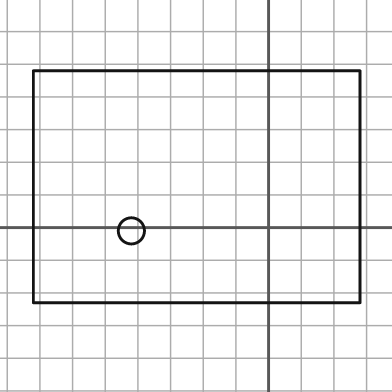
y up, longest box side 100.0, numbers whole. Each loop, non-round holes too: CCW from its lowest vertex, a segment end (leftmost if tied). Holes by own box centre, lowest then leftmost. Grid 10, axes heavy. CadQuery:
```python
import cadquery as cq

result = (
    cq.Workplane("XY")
    .moveTo(-72.0, -23.0)
    .lineTo(28.0, -23.0)
    .lineTo(28.0, 48.0)
    .lineTo(-72.0, 48.0)
    .close()
    .moveTo(-42.0, -1.0)
    .circle(4.0)
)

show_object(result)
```